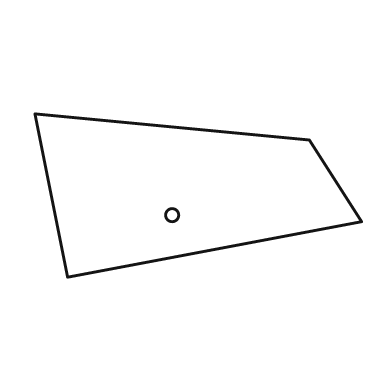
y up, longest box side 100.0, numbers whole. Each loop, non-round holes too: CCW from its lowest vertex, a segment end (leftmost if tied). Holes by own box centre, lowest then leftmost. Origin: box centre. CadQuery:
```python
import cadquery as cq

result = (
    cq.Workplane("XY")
    .moveTo(-40.0, -25.0)
    .lineTo(50.0, -8.0)
    .lineTo(34.0, 17.0)
    .lineTo(-50.0, 25.0)
    .close()
    .moveTo(-8.0, -6.0)
    .circle(2.0)
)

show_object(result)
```